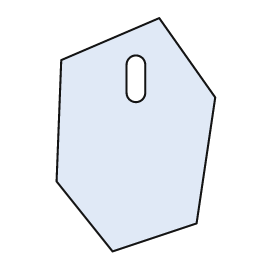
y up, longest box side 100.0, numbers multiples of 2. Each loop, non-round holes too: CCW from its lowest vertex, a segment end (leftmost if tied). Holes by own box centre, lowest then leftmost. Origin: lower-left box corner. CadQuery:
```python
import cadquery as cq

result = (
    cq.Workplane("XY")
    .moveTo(24.0, 0.0)
    .lineTo(60.0, 12.0)
    .lineTo(68.0, 66.0)
    .lineTo(44.0, 100.0)
    .lineTo(2.0, 82.0)
    .lineTo(0.0, 30.0)
    .close()
    .moveTo(30.0, 68.0)
    .threePointArc((34.0, 64.0), (38.0, 68.0))
    .lineTo(38.0, 80.0)
    .threePointArc((34.0, 84.0), (30.0, 80.0))
    .close()
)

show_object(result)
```